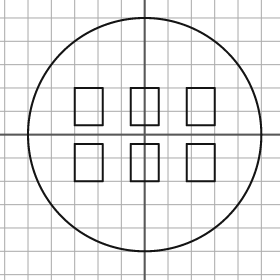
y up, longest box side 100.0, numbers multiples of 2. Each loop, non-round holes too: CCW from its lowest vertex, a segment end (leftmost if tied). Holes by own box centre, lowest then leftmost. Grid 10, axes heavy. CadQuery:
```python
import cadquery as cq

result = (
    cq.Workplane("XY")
    .moveTo(0.0, 0.0)
    .circle(50.0)
    .moveTo(-30.0, -20.0)
    .lineTo(-18.0, -20.0)
    .lineTo(-18.0, -4.0)
    .lineTo(-30.0, -4.0)
    .close()
    .moveTo(-6.0, -20.0)
    .lineTo(6.0, -20.0)
    .lineTo(6.0, -4.0)
    .lineTo(-6.0, -4.0)
    .close()
    .moveTo(18.0, -20.0)
    .lineTo(30.0, -20.0)
    .lineTo(30.0, -4.0)
    .lineTo(18.0, -4.0)
    .close()
    .moveTo(-30.0, 4.0)
    .lineTo(-18.0, 4.0)
    .lineTo(-18.0, 20.0)
    .lineTo(-30.0, 20.0)
    .close()
    .moveTo(-6.0, 4.0)
    .lineTo(6.0, 4.0)
    .lineTo(6.0, 20.0)
    .lineTo(-6.0, 20.0)
    .close()
    .moveTo(18.0, 4.0)
    .lineTo(30.0, 4.0)
    .lineTo(30.0, 20.0)
    .lineTo(18.0, 20.0)
    .close()
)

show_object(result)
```